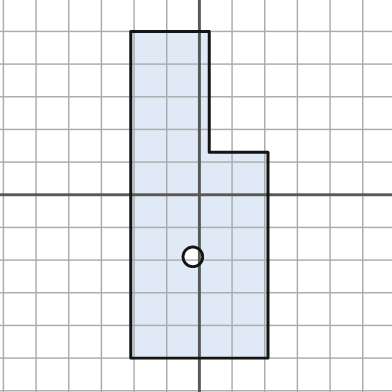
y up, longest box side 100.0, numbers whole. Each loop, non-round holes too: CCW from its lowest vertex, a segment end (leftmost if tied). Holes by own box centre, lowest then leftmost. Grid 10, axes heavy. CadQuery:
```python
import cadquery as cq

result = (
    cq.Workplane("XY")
    .moveTo(-21.0, -50.0)
    .lineTo(21.0, -50.0)
    .lineTo(21.0, 13.0)
    .lineTo(3.0, 13.0)
    .lineTo(3.0, 50.0)
    .lineTo(-21.0, 50.0)
    .close()
    .moveTo(-2.0, -19.0)
    .circle(3.0)
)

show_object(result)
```